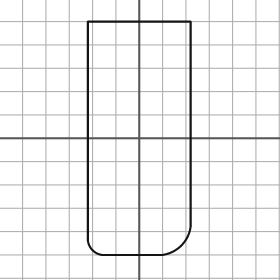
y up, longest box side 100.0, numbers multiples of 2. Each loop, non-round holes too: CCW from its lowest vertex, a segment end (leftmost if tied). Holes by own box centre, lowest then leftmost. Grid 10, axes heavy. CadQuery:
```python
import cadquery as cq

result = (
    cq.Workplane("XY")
    .moveTo(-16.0, -50.0)
    .lineTo(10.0, -50.0)
    .threePointArc((18.0, -46.0), (22.0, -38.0))
    .lineTo(22.0, 50.0)
    .lineTo(-22.0, 50.0)
    .lineTo(-22.0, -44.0)
    .threePointArc((-20.0, -48.0), (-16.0, -50.0))
    .close()
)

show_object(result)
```